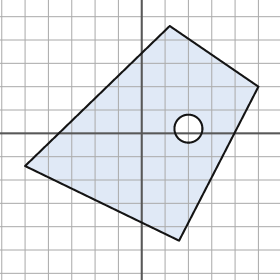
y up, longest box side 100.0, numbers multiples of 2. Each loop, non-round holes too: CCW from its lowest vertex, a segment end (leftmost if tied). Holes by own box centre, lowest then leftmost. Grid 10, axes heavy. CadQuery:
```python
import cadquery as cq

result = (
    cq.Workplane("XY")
    .moveTo(16.0, -46.0)
    .lineTo(50.0, 20.0)
    .lineTo(12.0, 46.0)
    .lineTo(-50.0, -14.0)
    .close()
    .moveTo(20.0, 2.0)
    .circle(6.0)
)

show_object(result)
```